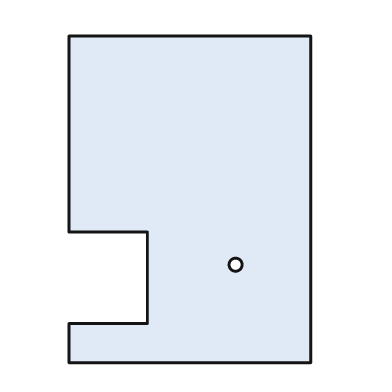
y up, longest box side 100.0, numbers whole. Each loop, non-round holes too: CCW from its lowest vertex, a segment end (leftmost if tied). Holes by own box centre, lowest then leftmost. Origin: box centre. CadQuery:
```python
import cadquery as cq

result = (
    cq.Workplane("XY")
    .moveTo(-37.0, -50.0)
    .lineTo(37.0, -50.0)
    .lineTo(37.0, 50.0)
    .lineTo(-37.0, 50.0)
    .lineTo(-37.0, -10.0)
    .lineTo(-13.0, -10.0)
    .lineTo(-13.0, -38.0)
    .lineTo(-37.0, -38.0)
    .close()
    .moveTo(14.0, -20.0)
    .circle(2.0)
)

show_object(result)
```